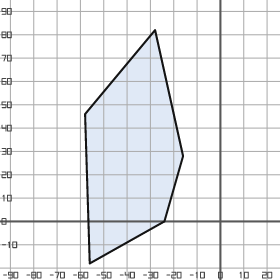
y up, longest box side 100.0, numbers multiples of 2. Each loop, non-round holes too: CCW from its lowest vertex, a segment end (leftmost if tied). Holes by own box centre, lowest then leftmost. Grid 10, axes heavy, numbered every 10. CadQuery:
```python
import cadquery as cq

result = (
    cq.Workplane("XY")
    .moveTo(-56.0, -18.0)
    .lineTo(-24.0, 0.0)
    .lineTo(-16.0, 28.0)
    .lineTo(-28.0, 82.0)
    .lineTo(-58.0, 46.0)
    .close()
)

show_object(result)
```